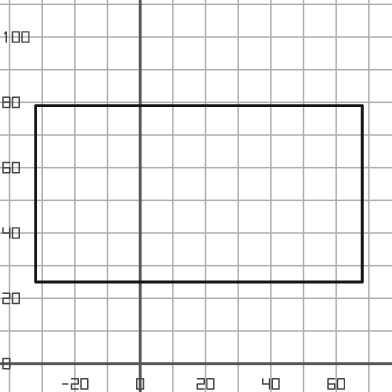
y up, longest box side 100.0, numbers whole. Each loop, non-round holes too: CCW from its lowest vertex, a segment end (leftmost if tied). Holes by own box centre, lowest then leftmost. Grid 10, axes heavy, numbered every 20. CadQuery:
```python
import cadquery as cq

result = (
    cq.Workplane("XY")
    .moveTo(-32.0, 25.0)
    .lineTo(68.0, 25.0)
    .lineTo(68.0, 79.0)
    .lineTo(-32.0, 79.0)
    .close()
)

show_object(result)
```